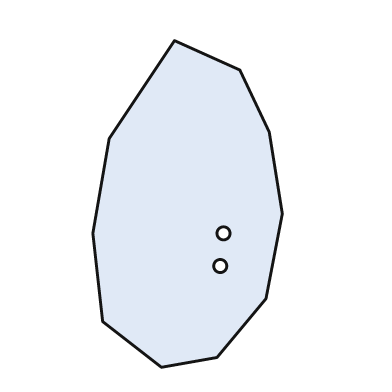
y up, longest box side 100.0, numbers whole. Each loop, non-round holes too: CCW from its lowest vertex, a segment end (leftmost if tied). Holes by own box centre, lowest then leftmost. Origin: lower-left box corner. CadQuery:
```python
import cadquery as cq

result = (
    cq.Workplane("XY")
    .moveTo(21.0, 0.0)
    .lineTo(38.0, 3.0)
    .lineTo(53.0, 21.0)
    .lineTo(58.0, 47.0)
    .lineTo(54.0, 72.0)
    .lineTo(45.0, 91.0)
    .lineTo(25.0, 100.0)
    .lineTo(5.0, 70.0)
    .lineTo(0.0, 41.0)
    .lineTo(3.0, 14.0)
    .close()
    .moveTo(39.0, 31.0)
    .circle(2.0)
    .moveTo(40.0, 41.0)
    .circle(2.0)
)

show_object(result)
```